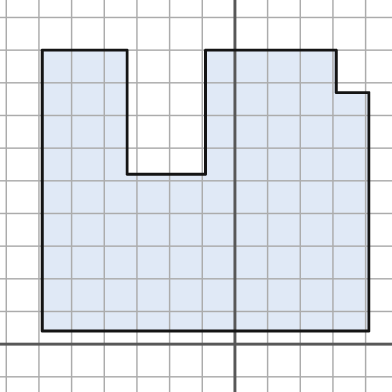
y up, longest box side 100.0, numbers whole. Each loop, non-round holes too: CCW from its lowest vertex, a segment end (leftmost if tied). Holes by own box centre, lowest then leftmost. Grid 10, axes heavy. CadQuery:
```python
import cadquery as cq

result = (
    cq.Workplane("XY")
    .moveTo(-59.0, 4.0)
    .lineTo(41.0, 4.0)
    .lineTo(41.0, 77.0)
    .lineTo(31.0, 77.0)
    .lineTo(31.0, 90.0)
    .lineTo(-9.0, 90.0)
    .lineTo(-9.0, 52.0)
    .lineTo(-33.0, 52.0)
    .lineTo(-33.0, 90.0)
    .lineTo(-59.0, 90.0)
    .close()
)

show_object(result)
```